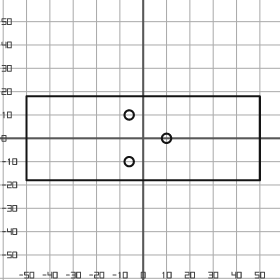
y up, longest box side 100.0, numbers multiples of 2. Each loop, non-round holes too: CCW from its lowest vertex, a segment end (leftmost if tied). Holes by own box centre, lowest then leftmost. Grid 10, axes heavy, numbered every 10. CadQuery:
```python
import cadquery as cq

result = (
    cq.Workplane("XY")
    .moveTo(-50.0, -18.0)
    .lineTo(50.0, -18.0)
    .lineTo(50.0, 18.0)
    .lineTo(-50.0, 18.0)
    .close()
    .moveTo(-6.0, -10.0)
    .circle(2.0)
    .moveTo(10.0, 0.0)
    .circle(2.0)
    .moveTo(-6.0, 10.0)
    .circle(2.0)
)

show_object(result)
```